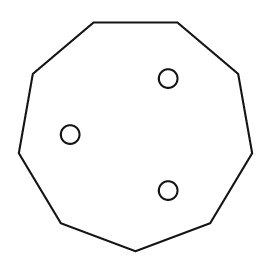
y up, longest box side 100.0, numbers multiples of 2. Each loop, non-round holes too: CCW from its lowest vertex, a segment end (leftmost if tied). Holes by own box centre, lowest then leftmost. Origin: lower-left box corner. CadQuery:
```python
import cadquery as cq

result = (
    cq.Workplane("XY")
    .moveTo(50.0, 0.0)
    .lineTo(82.0, 12.0)
    .lineTo(100.0, 42.0)
    .lineTo(94.0, 76.0)
    .lineTo(68.0, 98.0)
    .lineTo(32.0, 98.0)
    .lineTo(6.0, 76.0)
    .lineTo(0.0, 42.0)
    .lineTo(18.0, 12.0)
    .close()
    .moveTo(64.0, 26.0)
    .circle(4.0)
    .moveTo(22.0, 50.0)
    .circle(4.0)
    .moveTo(64.0, 74.0)
    .circle(4.0)
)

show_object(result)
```